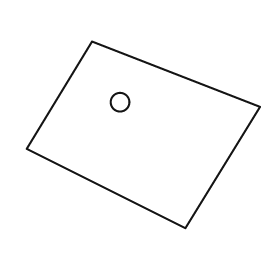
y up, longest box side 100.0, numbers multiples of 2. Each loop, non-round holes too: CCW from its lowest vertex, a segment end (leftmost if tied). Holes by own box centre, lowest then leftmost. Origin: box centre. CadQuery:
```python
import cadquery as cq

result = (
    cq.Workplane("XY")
    .moveTo(18.0, -40.0)
    .lineTo(50.0, 12.0)
    .lineTo(-22.0, 40.0)
    .lineTo(-50.0, -6.0)
    .close()
    .moveTo(-10.0, 14.0)
    .circle(4.0)
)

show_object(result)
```